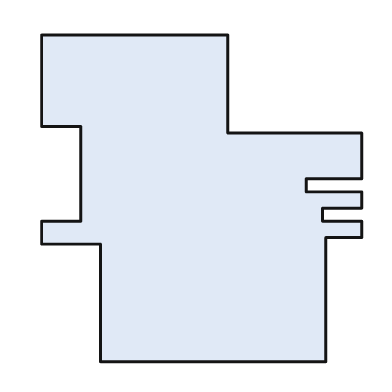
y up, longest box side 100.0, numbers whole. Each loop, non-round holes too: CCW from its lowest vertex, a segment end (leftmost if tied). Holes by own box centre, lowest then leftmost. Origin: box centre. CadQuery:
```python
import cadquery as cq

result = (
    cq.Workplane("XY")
    .moveTo(-31.0, -50.0)
    .lineTo(38.0, -50.0)
    .lineTo(38.0, -12.0)
    .lineTo(49.0, -12.0)
    .lineTo(49.0, -7.0)
    .lineTo(37.0, -7.0)
    .lineTo(37.0, -3.0)
    .lineTo(49.0, -3.0)
    .lineTo(49.0, 2.0)
    .lineTo(32.0, 2.0)
    .lineTo(32.0, 6.0)
    .lineTo(49.0, 6.0)
    .lineTo(49.0, 20.0)
    .lineTo(8.0, 20.0)
    .lineTo(8.0, 50.0)
    .lineTo(-49.0, 50.0)
    .lineTo(-49.0, 22.0)
    .lineTo(-37.0, 22.0)
    .lineTo(-37.0, -7.0)
    .lineTo(-49.0, -7.0)
    .lineTo(-49.0, -14.0)
    .lineTo(-31.0, -14.0)
    .close()
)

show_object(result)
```